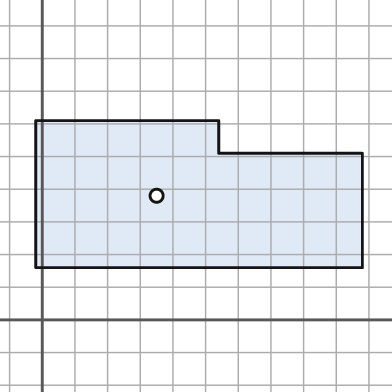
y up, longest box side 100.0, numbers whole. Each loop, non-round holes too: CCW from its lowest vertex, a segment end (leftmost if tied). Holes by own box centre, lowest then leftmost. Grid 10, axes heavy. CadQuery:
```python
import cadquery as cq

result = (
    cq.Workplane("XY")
    .moveTo(-2.0, 16.0)
    .lineTo(98.0, 16.0)
    .lineTo(98.0, 51.0)
    .lineTo(54.0, 51.0)
    .lineTo(54.0, 61.0)
    .lineTo(-2.0, 61.0)
    .close()
    .moveTo(35.0, 38.0)
    .circle(2.0)
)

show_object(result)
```